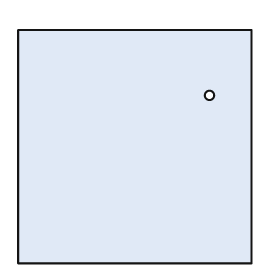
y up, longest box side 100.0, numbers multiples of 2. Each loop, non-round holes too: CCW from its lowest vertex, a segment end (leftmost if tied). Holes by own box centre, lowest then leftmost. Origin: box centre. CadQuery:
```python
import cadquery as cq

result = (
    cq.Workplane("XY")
    .moveTo(-50.0, -50.0)
    .lineTo(50.0, -50.0)
    .lineTo(50.0, 50.0)
    .lineTo(-50.0, 50.0)
    .close()
    .moveTo(32.0, 22.0)
    .circle(2.0)
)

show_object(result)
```